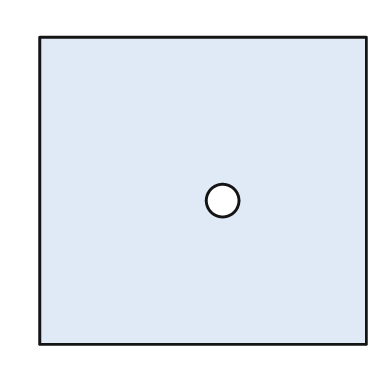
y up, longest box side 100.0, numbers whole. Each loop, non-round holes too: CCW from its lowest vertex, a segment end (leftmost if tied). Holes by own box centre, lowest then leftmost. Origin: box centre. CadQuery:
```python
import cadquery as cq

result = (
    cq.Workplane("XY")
    .moveTo(-50.0, -47.0)
    .lineTo(50.0, -47.0)
    .lineTo(50.0, 47.0)
    .lineTo(-50.0, 47.0)
    .close()
    .moveTo(6.0, -3.0)
    .circle(5.0)
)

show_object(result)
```